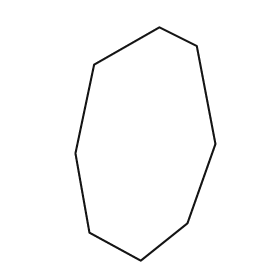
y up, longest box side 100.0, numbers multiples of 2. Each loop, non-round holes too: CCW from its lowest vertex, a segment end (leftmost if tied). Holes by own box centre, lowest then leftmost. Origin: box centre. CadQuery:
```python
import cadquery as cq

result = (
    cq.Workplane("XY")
    .moveTo(-2.0, -50.0)
    .lineTo(18.0, -34.0)
    .lineTo(30.0, 0.0)
    .lineTo(22.0, 42.0)
    .lineTo(6.0, 50.0)
    .lineTo(-22.0, 34.0)
    .lineTo(-30.0, -4.0)
    .lineTo(-24.0, -38.0)
    .close()
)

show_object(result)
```